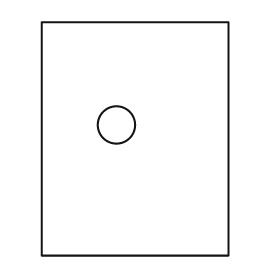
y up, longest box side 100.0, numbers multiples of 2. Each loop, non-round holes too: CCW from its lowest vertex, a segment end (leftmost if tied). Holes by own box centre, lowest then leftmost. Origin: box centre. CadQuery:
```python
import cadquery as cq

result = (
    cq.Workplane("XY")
    .moveTo(-40.0, -50.0)
    .lineTo(40.0, -50.0)
    .lineTo(40.0, 50.0)
    .lineTo(-40.0, 50.0)
    .close()
    .moveTo(-8.0, 6.0)
    .circle(8.0)
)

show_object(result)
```